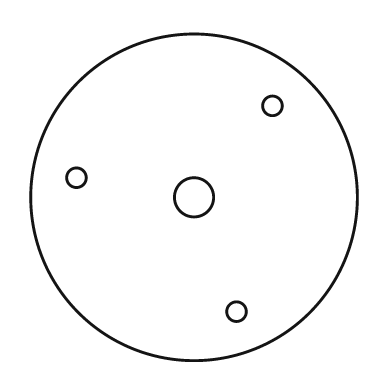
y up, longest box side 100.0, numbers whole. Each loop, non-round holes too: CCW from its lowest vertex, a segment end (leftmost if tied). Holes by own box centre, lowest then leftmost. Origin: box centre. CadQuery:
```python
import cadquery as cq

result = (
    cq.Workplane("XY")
    .moveTo(0.0, 0.0)
    .circle(50.0)
    .moveTo(13.0, -35.0)
    .circle(3.0)
    .moveTo(0.0, 0.0)
    .circle(6.0)
    .moveTo(-36.0, 6.0)
    .circle(3.0)
    .moveTo(24.0, 28.0)
    .circle(3.0)
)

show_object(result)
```